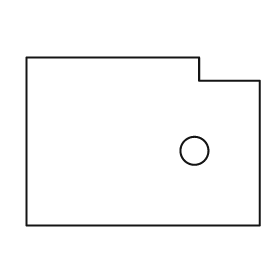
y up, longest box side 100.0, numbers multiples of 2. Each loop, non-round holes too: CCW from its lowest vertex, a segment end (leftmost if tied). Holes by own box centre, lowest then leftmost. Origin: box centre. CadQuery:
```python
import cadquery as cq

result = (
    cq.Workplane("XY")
    .moveTo(-50.0, -36.0)
    .lineTo(50.0, -36.0)
    .lineTo(50.0, 26.0)
    .lineTo(24.0, 26.0)
    .lineTo(24.0, 36.0)
    .lineTo(-50.0, 36.0)
    .close()
    .moveTo(22.0, -4.0)
    .circle(6.0)
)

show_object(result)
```